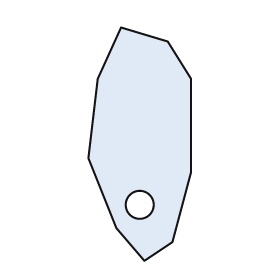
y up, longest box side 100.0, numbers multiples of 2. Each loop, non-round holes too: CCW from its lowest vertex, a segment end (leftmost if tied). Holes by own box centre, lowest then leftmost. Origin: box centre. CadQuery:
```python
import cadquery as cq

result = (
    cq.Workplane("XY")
    .moveTo(2.0, -50.0)
    .lineTo(14.0, -42.0)
    .lineTo(22.0, -12.0)
    .lineTo(22.0, 28.0)
    .lineTo(12.0, 44.0)
    .lineTo(-8.0, 50.0)
    .lineTo(-18.0, 28.0)
    .lineTo(-22.0, -6.0)
    .lineTo(-10.0, -36.0)
    .close()
    .moveTo(0.0, -26.0)
    .circle(6.0)
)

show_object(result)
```